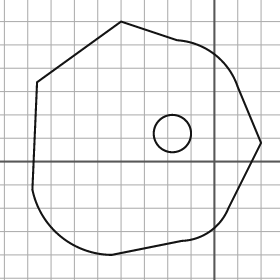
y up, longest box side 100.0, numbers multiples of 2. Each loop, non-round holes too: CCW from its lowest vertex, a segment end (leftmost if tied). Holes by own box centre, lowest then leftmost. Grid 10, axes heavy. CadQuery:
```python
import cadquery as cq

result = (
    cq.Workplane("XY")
    .moveTo(-44.0, -40.0)
    .lineTo(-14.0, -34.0)
    .threePointArc((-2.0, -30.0), (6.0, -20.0))
    .lineTo(20.0, 8.0)
    .lineTo(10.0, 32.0)
    .threePointArc((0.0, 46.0), (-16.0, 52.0))
    .lineTo(-40.0, 60.0)
    .lineTo(-76.0, 34.0)
    .lineTo(-78.0, -12.0)
    .threePointArc((-66.0, -32.0), (-44.0, -40.0))
    .close()
    .moveTo(-18.0, 12.0)
    .circle(8.0)
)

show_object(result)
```